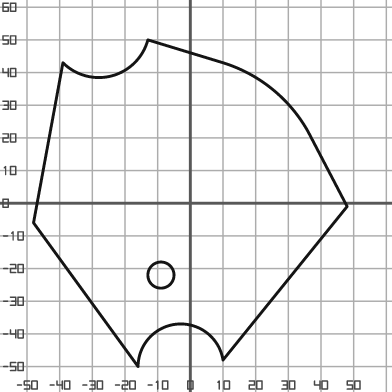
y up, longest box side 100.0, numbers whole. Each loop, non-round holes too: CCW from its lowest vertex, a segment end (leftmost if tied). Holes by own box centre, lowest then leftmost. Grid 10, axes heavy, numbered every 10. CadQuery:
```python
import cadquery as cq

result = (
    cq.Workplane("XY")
    .moveTo(-16.0, -50.0)
    .threePointArc((-4.0, -37.0), (10.0, -48.0))
    .lineTo(48.0, -1.0)
    .lineTo(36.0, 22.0)
    .threePointArc((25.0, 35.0), (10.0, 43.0))
    .lineTo(-13.0, 50.0)
    .threePointArc((-24.0, 39.0), (-39.0, 43.0))
    .lineTo(-48.0, -6.0)
    .close()
    .moveTo(-9.0, -22.0)
    .circle(4.0)
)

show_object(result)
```